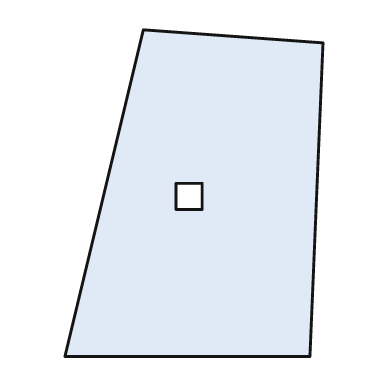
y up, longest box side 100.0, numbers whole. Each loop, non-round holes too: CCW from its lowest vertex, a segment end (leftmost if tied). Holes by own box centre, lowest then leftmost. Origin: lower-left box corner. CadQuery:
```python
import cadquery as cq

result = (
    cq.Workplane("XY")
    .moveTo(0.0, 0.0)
    .lineTo(75.0, 0.0)
    .lineTo(79.0, 96.0)
    .lineTo(24.0, 100.0)
    .close()
    .moveTo(34.0, 45.0)
    .lineTo(42.0, 45.0)
    .lineTo(42.0, 53.0)
    .lineTo(34.0, 53.0)
    .close()
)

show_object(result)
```